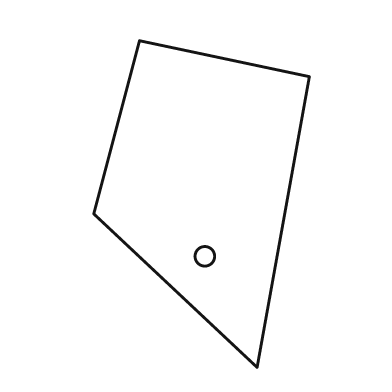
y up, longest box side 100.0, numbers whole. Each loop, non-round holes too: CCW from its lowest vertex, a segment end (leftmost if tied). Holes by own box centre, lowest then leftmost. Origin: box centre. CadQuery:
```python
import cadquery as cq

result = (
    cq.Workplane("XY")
    .moveTo(17.0, -50.0)
    .lineTo(33.0, 39.0)
    .lineTo(-19.0, 50.0)
    .lineTo(-33.0, -3.0)
    .close()
    .moveTo(1.0, -16.0)
    .circle(3.0)
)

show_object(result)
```